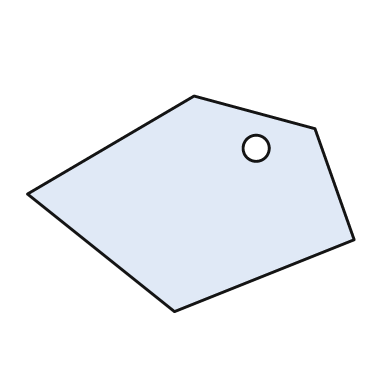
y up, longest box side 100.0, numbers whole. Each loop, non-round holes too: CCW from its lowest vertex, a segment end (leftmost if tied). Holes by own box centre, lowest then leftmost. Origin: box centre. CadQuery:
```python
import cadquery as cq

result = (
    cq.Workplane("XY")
    .moveTo(-5.0, -33.0)
    .lineTo(50.0, -11.0)
    .lineTo(38.0, 23.0)
    .lineTo(1.0, 33.0)
    .lineTo(-50.0, 3.0)
    .close()
    .moveTo(20.0, 17.0)
    .circle(4.0)
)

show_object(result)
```